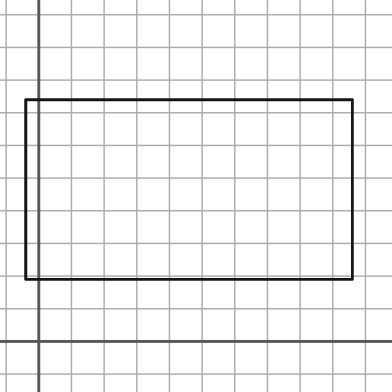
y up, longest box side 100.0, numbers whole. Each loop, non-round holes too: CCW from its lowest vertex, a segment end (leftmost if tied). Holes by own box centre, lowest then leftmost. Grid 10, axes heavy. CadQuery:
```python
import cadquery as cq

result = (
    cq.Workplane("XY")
    .moveTo(-4.0, 19.0)
    .lineTo(96.0, 19.0)
    .lineTo(96.0, 74.0)
    .lineTo(-4.0, 74.0)
    .close()
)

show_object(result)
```